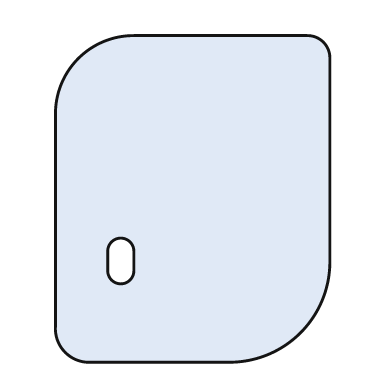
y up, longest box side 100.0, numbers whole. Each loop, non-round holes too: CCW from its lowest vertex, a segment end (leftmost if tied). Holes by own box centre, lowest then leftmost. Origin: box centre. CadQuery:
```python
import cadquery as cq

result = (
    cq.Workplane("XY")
    .moveTo(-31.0, -50.0)
    .lineTo(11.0, -50.0)
    .threePointArc((33.0, -41.0), (42.0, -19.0))
    .lineTo(42.0, 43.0)
    .threePointArc((40.0, 48.0), (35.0, 50.0))
    .lineTo(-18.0, 50.0)
    .threePointArc((-35.0, 43.0), (-42.0, 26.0))
    .lineTo(-42.0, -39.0)
    .threePointArc((-39.0, -47.0), (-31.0, -50.0))
    .close()
    .moveTo(-26.0, -22.0)
    .threePointArc((-22.0, -26.0), (-18.0, -22.0))
    .lineTo(-18.0, -16.0)
    .threePointArc((-22.0, -12.0), (-26.0, -16.0))
    .close()
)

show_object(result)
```